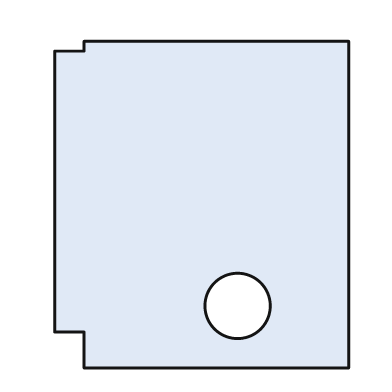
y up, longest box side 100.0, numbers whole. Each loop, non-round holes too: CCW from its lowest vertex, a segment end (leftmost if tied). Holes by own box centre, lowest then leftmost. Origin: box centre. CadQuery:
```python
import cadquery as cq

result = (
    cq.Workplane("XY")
    .moveTo(-36.0, -50.0)
    .lineTo(45.0, -50.0)
    .lineTo(45.0, 50.0)
    .lineTo(-36.0, 50.0)
    .lineTo(-36.0, 47.0)
    .lineTo(-45.0, 47.0)
    .lineTo(-45.0, -39.0)
    .lineTo(-36.0, -39.0)
    .close()
    .moveTo(11.0, -31.0)
    .circle(10.0)
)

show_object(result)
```